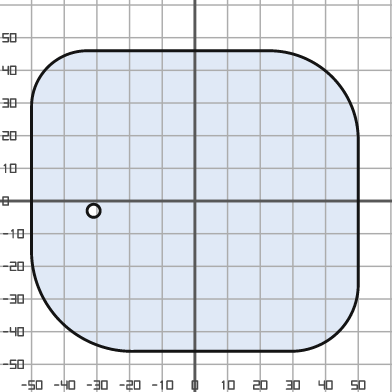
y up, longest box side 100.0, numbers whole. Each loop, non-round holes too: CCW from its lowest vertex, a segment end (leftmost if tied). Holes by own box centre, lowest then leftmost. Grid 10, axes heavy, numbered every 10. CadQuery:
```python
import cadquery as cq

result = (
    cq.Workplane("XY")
    .moveTo(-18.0, -46.0)
    .lineTo(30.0, -46.0)
    .threePointArc((44.0, -40.0), (50.0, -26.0))
    .lineTo(50.0, 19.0)
    .threePointArc((42.0, 38.0), (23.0, 46.0))
    .lineTo(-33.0, 46.0)
    .threePointArc((-45.0, 41.0), (-50.0, 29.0))
    .lineTo(-50.0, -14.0)
    .threePointArc((-41.0, -37.0), (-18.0, -46.0))
    .close()
    .moveTo(-31.0, -3.0)
    .circle(2.0)
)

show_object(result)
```